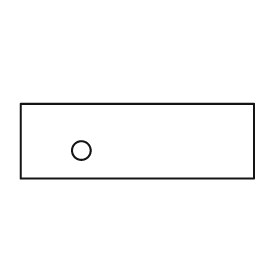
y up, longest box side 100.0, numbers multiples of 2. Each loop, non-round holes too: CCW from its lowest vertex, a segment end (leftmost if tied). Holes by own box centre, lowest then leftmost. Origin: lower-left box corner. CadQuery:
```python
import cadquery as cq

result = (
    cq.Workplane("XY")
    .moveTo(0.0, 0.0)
    .lineTo(100.0, 0.0)
    .lineTo(100.0, 32.0)
    .lineTo(0.0, 32.0)
    .close()
    .moveTo(26.0, 12.0)
    .circle(4.0)
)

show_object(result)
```